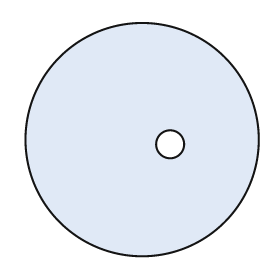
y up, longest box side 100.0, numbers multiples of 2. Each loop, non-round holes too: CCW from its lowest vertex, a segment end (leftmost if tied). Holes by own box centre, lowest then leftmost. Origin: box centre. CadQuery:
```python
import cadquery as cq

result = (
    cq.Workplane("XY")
    .moveTo(0.0, 0.0)
    .circle(50.0)
    .moveTo(12.0, -2.0)
    .circle(6.0)
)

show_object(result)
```